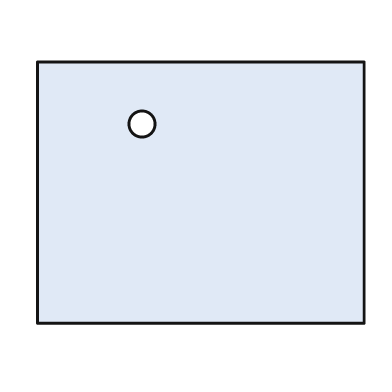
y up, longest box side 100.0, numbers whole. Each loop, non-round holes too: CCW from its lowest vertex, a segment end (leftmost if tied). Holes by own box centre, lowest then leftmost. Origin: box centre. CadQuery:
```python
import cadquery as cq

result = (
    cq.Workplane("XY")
    .moveTo(-50.0, -40.0)
    .lineTo(50.0, -40.0)
    .lineTo(50.0, 40.0)
    .lineTo(-50.0, 40.0)
    .close()
    .moveTo(-18.0, 21.0)
    .circle(4.0)
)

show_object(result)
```